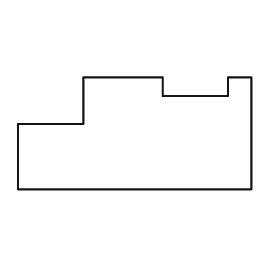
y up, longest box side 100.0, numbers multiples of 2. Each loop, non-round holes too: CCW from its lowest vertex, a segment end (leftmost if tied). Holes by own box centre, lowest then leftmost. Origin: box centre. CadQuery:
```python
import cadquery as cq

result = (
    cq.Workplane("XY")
    .moveTo(-50.0, -24.0)
    .lineTo(50.0, -24.0)
    .lineTo(50.0, 24.0)
    .lineTo(40.0, 24.0)
    .lineTo(40.0, 16.0)
    .lineTo(12.0, 16.0)
    .lineTo(12.0, 24.0)
    .lineTo(-22.0, 24.0)
    .lineTo(-22.0, 4.0)
    .lineTo(-50.0, 4.0)
    .close()
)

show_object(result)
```